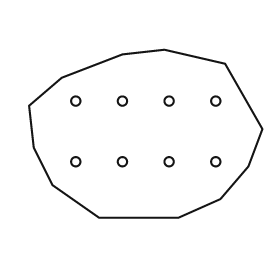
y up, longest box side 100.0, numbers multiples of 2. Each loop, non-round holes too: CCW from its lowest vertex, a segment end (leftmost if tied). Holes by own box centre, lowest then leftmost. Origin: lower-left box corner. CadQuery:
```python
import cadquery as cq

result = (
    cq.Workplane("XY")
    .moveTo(30.0, 0.0)
    .lineTo(64.0, 0.0)
    .lineTo(82.0, 8.0)
    .lineTo(94.0, 22.0)
    .lineTo(100.0, 38.0)
    .lineTo(84.0, 66.0)
    .lineTo(58.0, 72.0)
    .lineTo(40.0, 70.0)
    .lineTo(14.0, 60.0)
    .lineTo(0.0, 48.0)
    .lineTo(2.0, 30.0)
    .lineTo(10.0, 14.0)
    .close()
    .moveTo(20.0, 24.0)
    .circle(2.0)
    .moveTo(40.0, 24.0)
    .circle(2.0)
    .moveTo(60.0, 24.0)
    .circle(2.0)
    .moveTo(80.0, 24.0)
    .circle(2.0)
    .moveTo(20.0, 50.0)
    .circle(2.0)
    .moveTo(40.0, 50.0)
    .circle(2.0)
    .moveTo(60.0, 50.0)
    .circle(2.0)
    .moveTo(80.0, 50.0)
    .circle(2.0)
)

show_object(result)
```